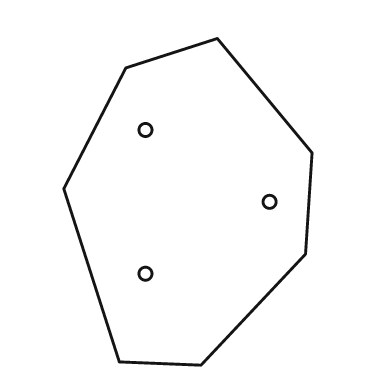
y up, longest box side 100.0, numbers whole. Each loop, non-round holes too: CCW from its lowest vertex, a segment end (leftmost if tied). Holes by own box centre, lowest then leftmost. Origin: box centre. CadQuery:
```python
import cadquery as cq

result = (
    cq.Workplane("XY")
    .moveTo(4.0, -50.0)
    .lineTo(36.0, -16.0)
    .lineTo(38.0, 15.0)
    .lineTo(9.0, 50.0)
    .lineTo(-19.0, 41.0)
    .lineTo(-38.0, 4.0)
    .lineTo(-21.0, -49.0)
    .close()
    .moveTo(-13.0, -22.0)
    .circle(2.0)
    .moveTo(25.0, 0.0)
    .circle(2.0)
    .moveTo(-13.0, 22.0)
    .circle(2.0)
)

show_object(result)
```